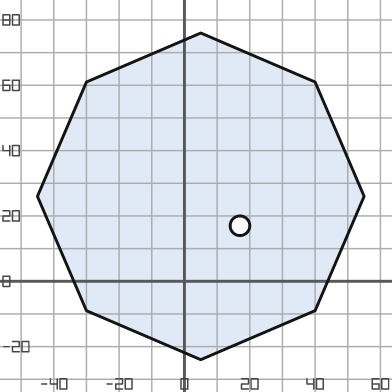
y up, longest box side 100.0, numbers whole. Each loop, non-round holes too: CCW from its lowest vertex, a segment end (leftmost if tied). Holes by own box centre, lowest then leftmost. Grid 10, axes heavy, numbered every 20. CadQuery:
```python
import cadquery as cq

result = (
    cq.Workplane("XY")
    .moveTo(5.0, -24.0)
    .lineTo(40.0, -9.0)
    .lineTo(55.0, 26.0)
    .lineTo(40.0, 61.0)
    .lineTo(5.0, 76.0)
    .lineTo(-30.0, 61.0)
    .lineTo(-45.0, 26.0)
    .lineTo(-30.0, -9.0)
    .close()
    .moveTo(17.0, 17.0)
    .circle(3.0)
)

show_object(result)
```